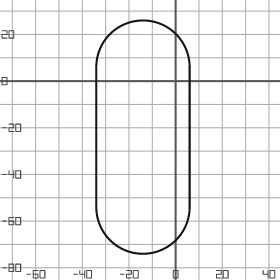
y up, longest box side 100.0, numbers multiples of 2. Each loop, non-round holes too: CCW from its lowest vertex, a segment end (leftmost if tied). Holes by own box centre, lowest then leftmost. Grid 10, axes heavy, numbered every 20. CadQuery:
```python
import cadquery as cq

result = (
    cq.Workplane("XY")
    .moveTo(-34.0, -54.0)
    .threePointArc((-14.0, -74.0), (6.0, -54.0))
    .lineTo(6.0, 6.0)
    .threePointArc((-14.0, 26.0), (-34.0, 6.0))
    .close()
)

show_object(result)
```